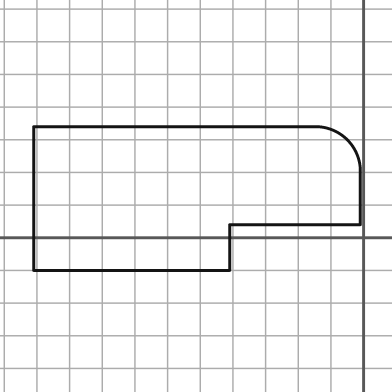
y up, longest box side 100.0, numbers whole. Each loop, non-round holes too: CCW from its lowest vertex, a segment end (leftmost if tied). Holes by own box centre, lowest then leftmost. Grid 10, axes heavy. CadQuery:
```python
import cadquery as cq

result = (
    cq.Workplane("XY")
    .moveTo(-101.0, -10.0)
    .lineTo(-41.0, -10.0)
    .lineTo(-41.0, 4.0)
    .lineTo(-1.0, 4.0)
    .lineTo(-1.0, 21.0)
    .threePointArc((-5.0, 30.0), (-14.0, 34.0))
    .lineTo(-101.0, 34.0)
    .close()
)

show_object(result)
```